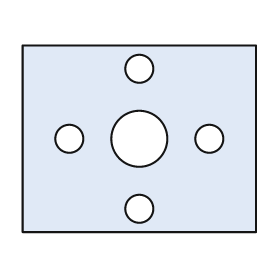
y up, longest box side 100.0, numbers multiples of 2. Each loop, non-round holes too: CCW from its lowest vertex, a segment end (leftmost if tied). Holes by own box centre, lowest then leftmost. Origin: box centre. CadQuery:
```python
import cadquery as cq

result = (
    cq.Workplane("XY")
    .moveTo(-50.0, -40.0)
    .lineTo(50.0, -40.0)
    .lineTo(50.0, 40.0)
    .lineTo(-50.0, 40.0)
    .close()
    .moveTo(0.0, -30.0)
    .circle(6.0)
    .moveTo(-30.0, 0.0)
    .circle(6.0)
    .moveTo(0.0, 0.0)
    .circle(12.0)
    .moveTo(30.0, 0.0)
    .circle(6.0)
    .moveTo(0.0, 30.0)
    .circle(6.0)
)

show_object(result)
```